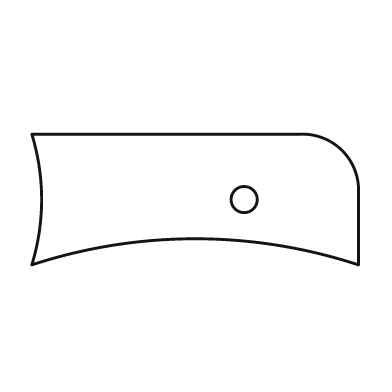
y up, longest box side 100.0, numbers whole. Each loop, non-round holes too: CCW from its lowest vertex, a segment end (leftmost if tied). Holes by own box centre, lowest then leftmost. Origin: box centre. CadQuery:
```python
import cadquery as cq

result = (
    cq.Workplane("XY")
    .moveTo(-50.0, -20.0)
    .threePointArc((0.0, -12.0), (50.0, -20.0))
    .lineTo(50.0, 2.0)
    .threePointArc((45.0, 15.0), (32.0, 20.0))
    .lineTo(-50.0, 20.0)
    .threePointArc((-47.0, 0.0), (-50.0, -20.0))
    .close()
    .moveTo(15.0, 0.0)
    .circle(4.0)
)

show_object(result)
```